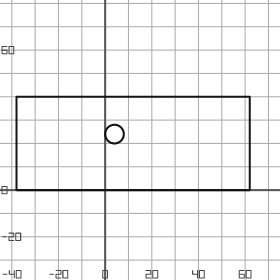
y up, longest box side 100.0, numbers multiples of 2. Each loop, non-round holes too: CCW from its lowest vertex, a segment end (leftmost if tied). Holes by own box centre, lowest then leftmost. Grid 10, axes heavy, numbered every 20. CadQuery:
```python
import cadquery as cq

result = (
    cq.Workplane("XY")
    .moveTo(-38.0, 0.0)
    .lineTo(62.0, 0.0)
    .lineTo(62.0, 40.0)
    .lineTo(-38.0, 40.0)
    .close()
    .moveTo(4.0, 24.0)
    .circle(4.0)
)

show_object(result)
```